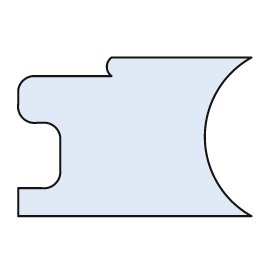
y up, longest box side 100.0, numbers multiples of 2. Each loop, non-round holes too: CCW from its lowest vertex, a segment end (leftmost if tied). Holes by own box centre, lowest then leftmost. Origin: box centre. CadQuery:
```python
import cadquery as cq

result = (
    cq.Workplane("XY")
    .moveTo(-50.0, -34.0)
    .lineTo(50.0, -34.0)
    .threePointArc((30.0, 0.0), (50.0, 34.0))
    .lineTo(-10.0, 34.0)
    .threePointArc((-12.0, 30.0), (-10.0, 26.0))
    .lineTo(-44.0, 26.0)
    .threePointArc((-48.0, 24.0), (-50.0, 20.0))
    .lineTo(-50.0, 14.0)
    .threePointArc((-48.0, 8.0), (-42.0, 6.0))
    .lineTo(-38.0, 6.0)
    .threePointArc((-34.0, 4.0), (-32.0, 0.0))
    .lineTo(-32.0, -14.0)
    .threePointArc((-34.0, -20.0), (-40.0, -22.0))
    .lineTo(-50.0, -22.0)
    .close()
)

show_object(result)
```